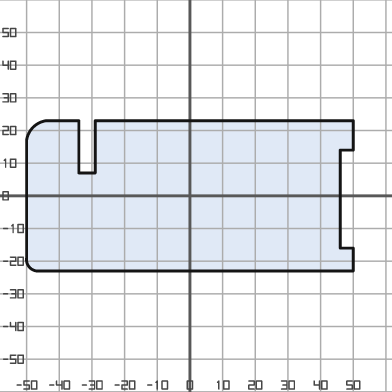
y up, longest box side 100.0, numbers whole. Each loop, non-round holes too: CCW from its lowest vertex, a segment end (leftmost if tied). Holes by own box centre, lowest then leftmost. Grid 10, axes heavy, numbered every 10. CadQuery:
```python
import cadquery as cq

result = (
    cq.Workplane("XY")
    .moveTo(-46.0, -23.0)
    .lineTo(50.0, -23.0)
    .lineTo(50.0, -16.0)
    .lineTo(46.0, -16.0)
    .lineTo(46.0, 14.0)
    .lineTo(50.0, 14.0)
    .lineTo(50.0, 23.0)
    .lineTo(-29.0, 23.0)
    .lineTo(-29.0, 7.0)
    .lineTo(-34.0, 7.0)
    .lineTo(-34.0, 23.0)
    .lineTo(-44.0, 23.0)
    .threePointArc((-48.0, 21.0), (-50.0, 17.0))
    .lineTo(-50.0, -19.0)
    .threePointArc((-49.0, -22.0), (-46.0, -23.0))
    .close()
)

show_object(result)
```